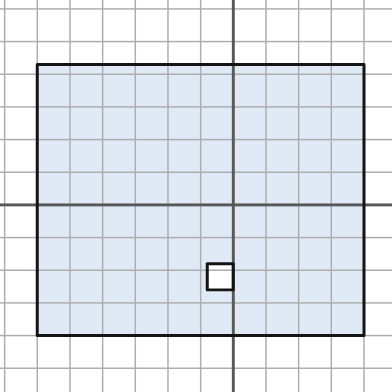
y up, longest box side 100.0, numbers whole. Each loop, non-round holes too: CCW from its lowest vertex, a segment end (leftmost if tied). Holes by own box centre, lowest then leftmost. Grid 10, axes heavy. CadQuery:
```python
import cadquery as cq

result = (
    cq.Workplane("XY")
    .moveTo(-60.0, -40.0)
    .lineTo(40.0, -40.0)
    .lineTo(40.0, 43.0)
    .lineTo(-60.0, 43.0)
    .close()
    .moveTo(-8.0, -26.0)
    .lineTo(0.0, -26.0)
    .lineTo(0.0, -18.0)
    .lineTo(-8.0, -18.0)
    .close()
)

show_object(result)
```